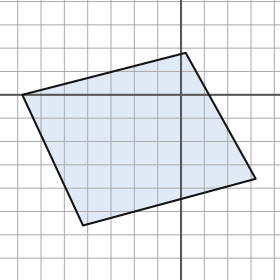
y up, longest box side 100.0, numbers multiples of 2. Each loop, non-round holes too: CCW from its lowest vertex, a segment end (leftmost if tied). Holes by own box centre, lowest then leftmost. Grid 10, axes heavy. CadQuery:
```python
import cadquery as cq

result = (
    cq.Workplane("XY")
    .moveTo(-42.0, -56.0)
    .lineTo(32.0, -36.0)
    .lineTo(2.0, 18.0)
    .lineTo(-68.0, 0.0)
    .close()
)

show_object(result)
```